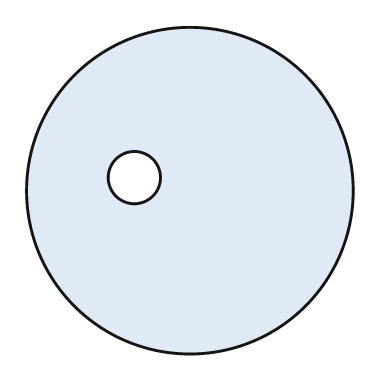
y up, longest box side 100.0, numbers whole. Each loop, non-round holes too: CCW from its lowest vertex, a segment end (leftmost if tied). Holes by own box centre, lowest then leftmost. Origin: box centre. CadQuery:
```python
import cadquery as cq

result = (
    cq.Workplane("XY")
    .moveTo(0.0, 0.0)
    .circle(50.0)
    .moveTo(-17.0, 4.0)
    .circle(8.0)
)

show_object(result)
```